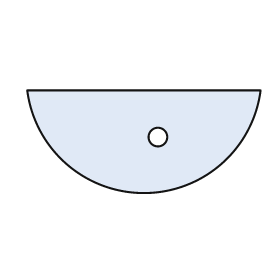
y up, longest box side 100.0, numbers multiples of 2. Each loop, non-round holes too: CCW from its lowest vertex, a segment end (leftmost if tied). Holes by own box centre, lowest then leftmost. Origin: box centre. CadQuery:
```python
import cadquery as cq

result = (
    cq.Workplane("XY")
    .moveTo(-50.0, 22.0)
    .threePointArc((0.0, -22.0), (50.0, 22.0))
    .close()
    .moveTo(6.0, 2.0)
    .circle(4.0)
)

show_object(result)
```